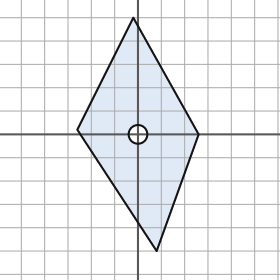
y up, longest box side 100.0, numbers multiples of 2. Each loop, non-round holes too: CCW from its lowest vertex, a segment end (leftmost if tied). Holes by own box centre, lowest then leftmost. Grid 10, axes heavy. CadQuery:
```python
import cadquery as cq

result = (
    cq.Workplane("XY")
    .moveTo(8.0, -50.0)
    .lineTo(26.0, 0.0)
    .lineTo(-2.0, 50.0)
    .lineTo(-26.0, 2.0)
    .close()
    .moveTo(0.0, 0.0)
    .circle(4.0)
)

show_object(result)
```